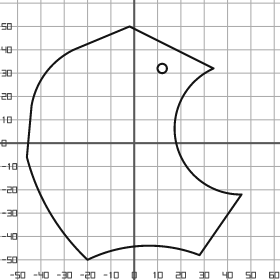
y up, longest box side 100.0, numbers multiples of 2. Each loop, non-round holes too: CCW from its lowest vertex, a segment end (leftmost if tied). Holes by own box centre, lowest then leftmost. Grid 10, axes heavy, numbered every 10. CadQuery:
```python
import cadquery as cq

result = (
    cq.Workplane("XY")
    .moveTo(-20.0, -50.0)
    .threePointArc((4.0, -44.0), (28.0, -48.0))
    .lineTo(46.0, -22.0)
    .threePointArc((18.0, 0.0), (34.0, 32.0))
    .lineTo(-2.0, 50.0)
    .lineTo(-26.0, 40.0)
    .threePointArc((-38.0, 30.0), (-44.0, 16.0))
    .lineTo(-46.0, -6.0)
    .threePointArc((-36.0, -30.0), (-20.0, -50.0))
    .close()
    .moveTo(12.0, 32.0)
    .circle(2.0)
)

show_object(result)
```